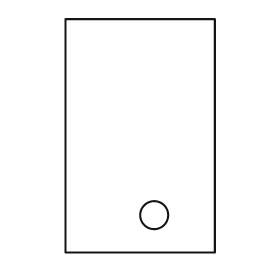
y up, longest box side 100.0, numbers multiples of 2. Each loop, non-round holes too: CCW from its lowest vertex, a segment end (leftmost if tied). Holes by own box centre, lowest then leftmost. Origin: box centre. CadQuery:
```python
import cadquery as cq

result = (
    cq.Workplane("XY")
    .moveTo(-32.0, -50.0)
    .lineTo(32.0, -50.0)
    .lineTo(32.0, 50.0)
    .lineTo(-32.0, 50.0)
    .close()
    .moveTo(6.0, -34.0)
    .circle(6.0)
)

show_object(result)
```